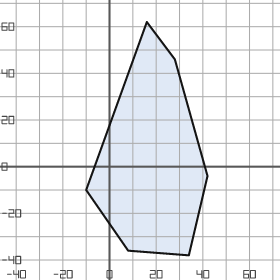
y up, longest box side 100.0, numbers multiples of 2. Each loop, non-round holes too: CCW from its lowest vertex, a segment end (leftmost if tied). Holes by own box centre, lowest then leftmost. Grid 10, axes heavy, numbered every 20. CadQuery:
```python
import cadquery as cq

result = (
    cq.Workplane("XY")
    .moveTo(34.0, -38.0)
    .lineTo(42.0, -4.0)
    .lineTo(28.0, 46.0)
    .lineTo(16.0, 62.0)
    .lineTo(-10.0, -10.0)
    .lineTo(8.0, -36.0)
    .close()
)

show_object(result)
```